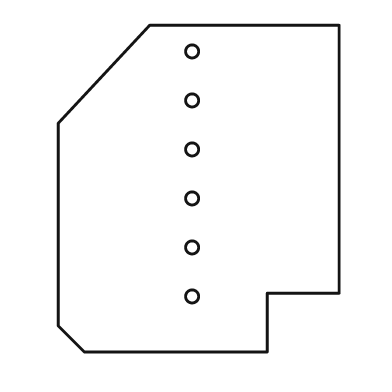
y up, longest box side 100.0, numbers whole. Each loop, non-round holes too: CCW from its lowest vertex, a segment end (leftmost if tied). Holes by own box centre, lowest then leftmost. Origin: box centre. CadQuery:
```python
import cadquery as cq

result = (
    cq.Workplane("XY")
    .moveTo(-35.0, -50.0)
    .lineTo(21.0, -50.0)
    .lineTo(21.0, -32.0)
    .lineTo(43.0, -32.0)
    .lineTo(43.0, 50.0)
    .lineTo(-15.0, 50.0)
    .lineTo(-43.0, 20.0)
    .lineTo(-43.0, -42.0)
    .close()
    .moveTo(-2.0, -33.0)
    .circle(2.0)
    .moveTo(-2.0, -18.0)
    .circle(2.0)
    .moveTo(-2.0, -3.0)
    .circle(2.0)
    .moveTo(-2.0, 12.0)
    .circle(2.0)
    .moveTo(-2.0, 27.0)
    .circle(2.0)
    .moveTo(-2.0, 42.0)
    .circle(2.0)
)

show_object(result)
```